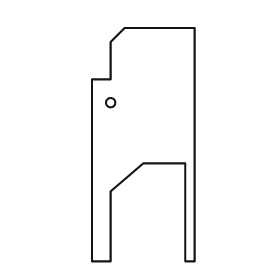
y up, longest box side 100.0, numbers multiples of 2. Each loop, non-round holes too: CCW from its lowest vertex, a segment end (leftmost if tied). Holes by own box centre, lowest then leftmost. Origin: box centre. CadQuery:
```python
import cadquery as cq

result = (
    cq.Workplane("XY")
    .moveTo(-22.0, -50.0)
    .lineTo(-14.0, -50.0)
    .lineTo(-14.0, -20.0)
    .lineTo(0.0, -8.0)
    .lineTo(18.0, -8.0)
    .lineTo(18.0, -50.0)
    .lineTo(22.0, -50.0)
    .lineTo(22.0, 50.0)
    .lineTo(-8.0, 50.0)
    .lineTo(-14.0, 44.0)
    .lineTo(-14.0, 28.0)
    .lineTo(-22.0, 28.0)
    .close()
    .moveTo(-14.0, 18.0)
    .circle(2.0)
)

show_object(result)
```